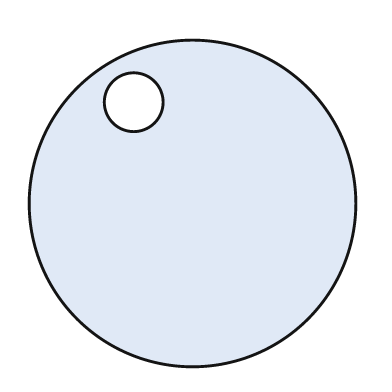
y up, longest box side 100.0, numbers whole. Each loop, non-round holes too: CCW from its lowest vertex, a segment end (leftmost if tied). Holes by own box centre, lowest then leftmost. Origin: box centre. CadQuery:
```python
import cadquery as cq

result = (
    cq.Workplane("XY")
    .moveTo(0.0, 0.0)
    .circle(50.0)
    .moveTo(-18.0, 31.0)
    .circle(9.0)
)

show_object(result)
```